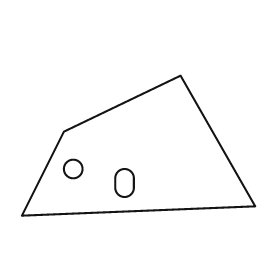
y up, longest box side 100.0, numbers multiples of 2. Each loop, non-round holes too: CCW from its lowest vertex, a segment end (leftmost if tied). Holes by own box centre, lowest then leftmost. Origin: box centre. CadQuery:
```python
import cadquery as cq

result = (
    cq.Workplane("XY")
    .moveTo(-50.0, -30.0)
    .lineTo(50.0, -26.0)
    .lineTo(18.0, 30.0)
    .lineTo(-32.0, 6.0)
    .close()
    .moveTo(-10.0, -18.0)
    .threePointArc((-6.0, -22.0), (-2.0, -18.0))
    .lineTo(-2.0, -14.0)
    .threePointArc((-6.0, -10.0), (-10.0, -14.0))
    .close()
    .moveTo(-28.0, -10.0)
    .circle(4.0)
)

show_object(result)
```